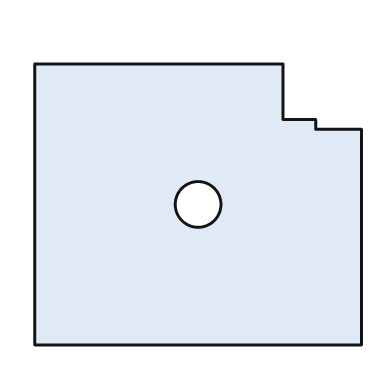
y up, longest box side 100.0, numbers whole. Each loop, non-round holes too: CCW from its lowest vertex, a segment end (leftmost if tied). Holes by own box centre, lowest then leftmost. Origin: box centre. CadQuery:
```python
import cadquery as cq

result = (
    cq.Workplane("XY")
    .moveTo(-50.0, -43.0)
    .lineTo(50.0, -43.0)
    .lineTo(50.0, 23.0)
    .lineTo(36.0, 23.0)
    .lineTo(36.0, 26.0)
    .lineTo(26.0, 26.0)
    .lineTo(26.0, 43.0)
    .lineTo(-50.0, 43.0)
    .close()
    .moveTo(0.0, 0.0)
    .circle(7.0)
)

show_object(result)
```